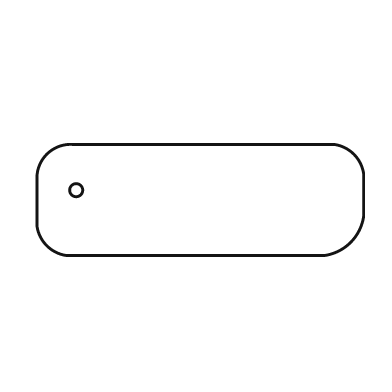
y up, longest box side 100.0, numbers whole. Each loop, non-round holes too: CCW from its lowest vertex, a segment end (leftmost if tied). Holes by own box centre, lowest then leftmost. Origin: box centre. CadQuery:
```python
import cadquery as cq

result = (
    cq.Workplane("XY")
    .moveTo(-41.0, -17.0)
    .lineTo(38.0, -17.0)
    .threePointArc((46.0, -13.0), (50.0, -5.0))
    .lineTo(50.0, 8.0)
    .threePointArc((47.0, 14.0), (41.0, 17.0))
    .lineTo(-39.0, 17.0)
    .threePointArc((-47.0, 14.0), (-50.0, 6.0))
    .lineTo(-50.0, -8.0)
    .threePointArc((-47.0, -14.0), (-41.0, -17.0))
    .close()
    .moveTo(-38.0, 3.0)
    .circle(2.0)
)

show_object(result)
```